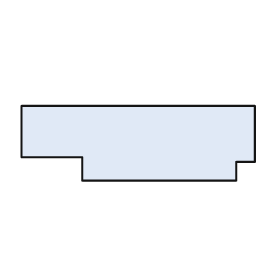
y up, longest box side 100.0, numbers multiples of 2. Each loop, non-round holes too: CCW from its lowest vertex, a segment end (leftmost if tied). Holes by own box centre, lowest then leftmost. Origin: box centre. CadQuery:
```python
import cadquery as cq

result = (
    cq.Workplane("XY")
    .moveTo(-24.0, -16.0)
    .lineTo(42.0, -16.0)
    .lineTo(42.0, -8.0)
    .lineTo(50.0, -8.0)
    .lineTo(50.0, 16.0)
    .lineTo(-50.0, 16.0)
    .lineTo(-50.0, -6.0)
    .lineTo(-24.0, -6.0)
    .close()
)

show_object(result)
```